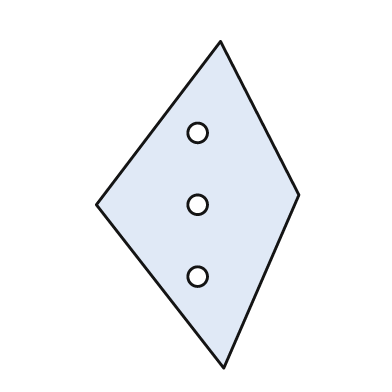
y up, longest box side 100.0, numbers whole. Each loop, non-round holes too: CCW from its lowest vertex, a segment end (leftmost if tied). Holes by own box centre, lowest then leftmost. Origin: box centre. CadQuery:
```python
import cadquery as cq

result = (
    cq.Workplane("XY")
    .moveTo(8.0, -50.0)
    .lineTo(31.0, 3.0)
    .lineTo(7.0, 50.0)
    .lineTo(-31.0, 0.0)
    .close()
    .moveTo(0.0, -22.0)
    .circle(3.0)
    .moveTo(0.0, 0.0)
    .circle(3.0)
    .moveTo(0.0, 22.0)
    .circle(3.0)
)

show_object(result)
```